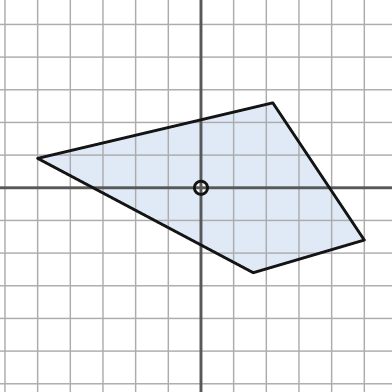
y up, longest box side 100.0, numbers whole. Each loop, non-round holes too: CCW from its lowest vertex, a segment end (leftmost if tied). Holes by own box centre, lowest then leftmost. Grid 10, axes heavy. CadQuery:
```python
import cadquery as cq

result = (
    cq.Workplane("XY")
    .moveTo(16.0, -26.0)
    .lineTo(50.0, -16.0)
    .lineTo(22.0, 26.0)
    .lineTo(-50.0, 9.0)
    .close()
    .moveTo(0.0, 0.0)
    .circle(2.0)
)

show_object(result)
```